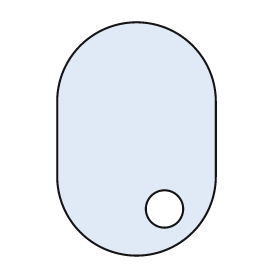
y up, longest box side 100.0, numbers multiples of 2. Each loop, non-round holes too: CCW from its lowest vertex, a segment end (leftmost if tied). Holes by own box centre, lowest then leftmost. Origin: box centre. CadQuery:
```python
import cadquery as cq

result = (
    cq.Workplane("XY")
    .moveTo(-34.0, -16.0)
    .threePointArc((0.0, -50.0), (34.0, -16.0))
    .lineTo(34.0, 16.0)
    .threePointArc((0.0, 50.0), (-34.0, 16.0))
    .close()
    .moveTo(12.0, -30.0)
    .circle(8.0)
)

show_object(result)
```